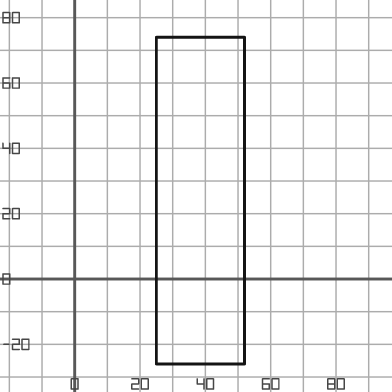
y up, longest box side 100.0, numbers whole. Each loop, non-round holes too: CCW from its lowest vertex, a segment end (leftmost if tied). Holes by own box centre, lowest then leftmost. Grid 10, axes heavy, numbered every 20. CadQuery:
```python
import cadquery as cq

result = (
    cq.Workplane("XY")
    .moveTo(25.0, -26.0)
    .lineTo(52.0, -26.0)
    .lineTo(52.0, 74.0)
    .lineTo(25.0, 74.0)
    .close()
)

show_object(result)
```